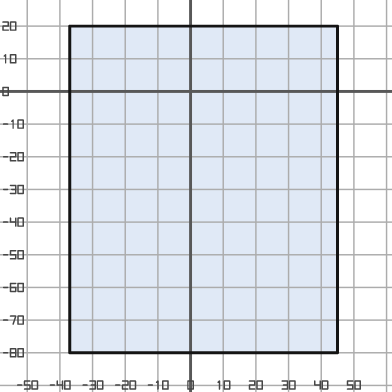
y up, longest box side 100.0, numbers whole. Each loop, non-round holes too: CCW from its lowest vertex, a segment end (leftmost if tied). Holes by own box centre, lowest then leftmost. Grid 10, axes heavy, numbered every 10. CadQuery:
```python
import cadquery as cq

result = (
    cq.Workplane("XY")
    .moveTo(-37.0, -80.0)
    .lineTo(45.0, -80.0)
    .lineTo(45.0, 20.0)
    .lineTo(-37.0, 20.0)
    .close()
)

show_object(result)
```